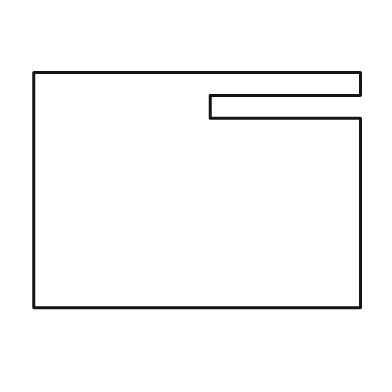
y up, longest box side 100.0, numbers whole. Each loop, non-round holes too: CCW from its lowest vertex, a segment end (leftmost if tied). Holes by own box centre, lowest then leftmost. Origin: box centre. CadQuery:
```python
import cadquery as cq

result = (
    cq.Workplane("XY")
    .moveTo(-50.0, -36.0)
    .lineTo(50.0, -36.0)
    .lineTo(50.0, 22.0)
    .lineTo(4.0, 22.0)
    .lineTo(4.0, 29.0)
    .lineTo(50.0, 29.0)
    .lineTo(50.0, 36.0)
    .lineTo(-50.0, 36.0)
    .close()
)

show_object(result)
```